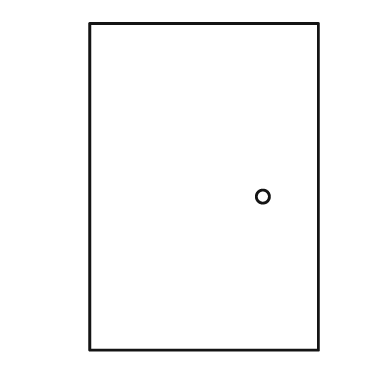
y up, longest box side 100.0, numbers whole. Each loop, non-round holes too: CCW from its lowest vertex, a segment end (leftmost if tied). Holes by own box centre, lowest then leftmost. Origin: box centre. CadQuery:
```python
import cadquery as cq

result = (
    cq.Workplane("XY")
    .moveTo(-35.0, -50.0)
    .lineTo(35.0, -50.0)
    .lineTo(35.0, 50.0)
    .lineTo(-35.0, 50.0)
    .close()
    .moveTo(18.0, -3.0)
    .circle(2.0)
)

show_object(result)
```